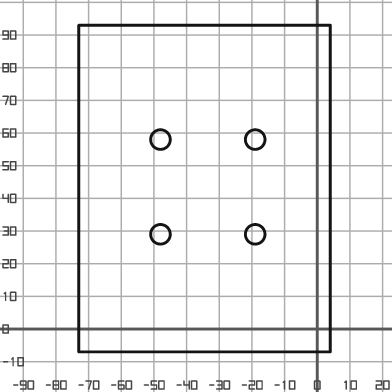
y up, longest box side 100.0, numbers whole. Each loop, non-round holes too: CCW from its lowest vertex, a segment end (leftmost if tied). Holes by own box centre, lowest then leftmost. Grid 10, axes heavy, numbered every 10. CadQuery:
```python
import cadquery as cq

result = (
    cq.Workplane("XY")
    .moveTo(-73.0, -7.0)
    .lineTo(4.0, -7.0)
    .lineTo(4.0, 93.0)
    .lineTo(-73.0, 93.0)
    .close()
    .moveTo(-48.0, 29.0)
    .circle(3.0)
    .moveTo(-19.0, 29.0)
    .circle(3.0)
    .moveTo(-48.0, 58.0)
    .circle(3.0)
    .moveTo(-19.0, 58.0)
    .circle(3.0)
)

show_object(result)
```